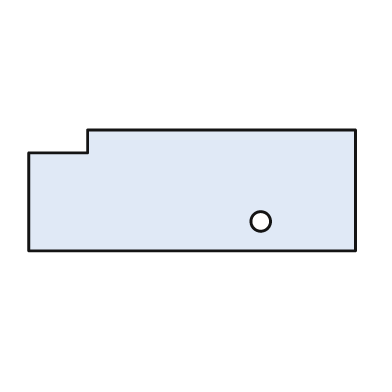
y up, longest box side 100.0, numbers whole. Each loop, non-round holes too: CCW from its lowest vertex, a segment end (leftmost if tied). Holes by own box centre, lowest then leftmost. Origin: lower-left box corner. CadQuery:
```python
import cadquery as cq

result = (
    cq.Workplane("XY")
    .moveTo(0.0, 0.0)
    .lineTo(100.0, 0.0)
    .lineTo(100.0, 37.0)
    .lineTo(18.0, 37.0)
    .lineTo(18.0, 30.0)
    .lineTo(0.0, 30.0)
    .close()
    .moveTo(71.0, 9.0)
    .circle(3.0)
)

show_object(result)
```